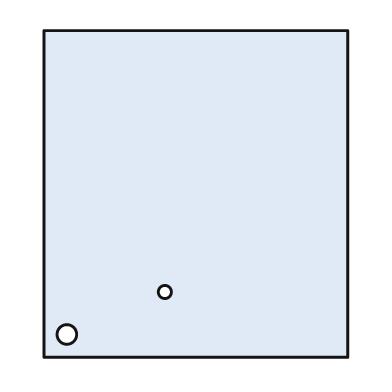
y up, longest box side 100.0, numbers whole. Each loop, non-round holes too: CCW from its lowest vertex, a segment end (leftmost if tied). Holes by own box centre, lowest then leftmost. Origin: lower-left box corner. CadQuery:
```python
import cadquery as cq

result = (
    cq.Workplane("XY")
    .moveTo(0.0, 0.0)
    .lineTo(93.0, 0.0)
    .lineTo(93.0, 100.0)
    .lineTo(0.0, 100.0)
    .close()
    .moveTo(7.0, 7.0)
    .circle(3.0)
    .moveTo(37.0, 20.0)
    .circle(2.0)
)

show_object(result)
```